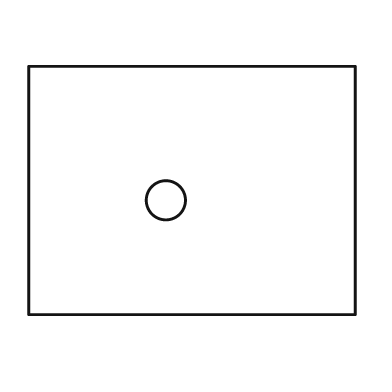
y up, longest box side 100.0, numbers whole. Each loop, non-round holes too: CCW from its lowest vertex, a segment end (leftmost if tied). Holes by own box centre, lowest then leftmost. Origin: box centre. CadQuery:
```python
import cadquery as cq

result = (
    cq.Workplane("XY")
    .moveTo(-50.0, -38.0)
    .lineTo(50.0, -38.0)
    .lineTo(50.0, 38.0)
    .lineTo(-50.0, 38.0)
    .close()
    .moveTo(-8.0, -3.0)
    .circle(6.0)
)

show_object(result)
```